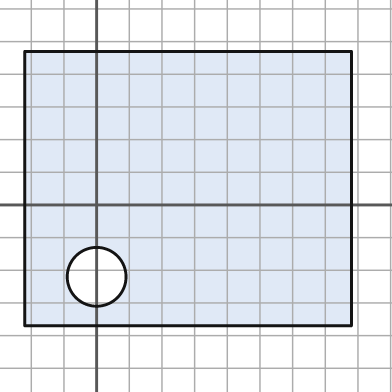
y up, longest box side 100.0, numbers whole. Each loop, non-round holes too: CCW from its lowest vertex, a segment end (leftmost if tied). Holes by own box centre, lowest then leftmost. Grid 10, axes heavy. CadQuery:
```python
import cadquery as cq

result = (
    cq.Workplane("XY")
    .moveTo(-22.0, -37.0)
    .lineTo(78.0, -37.0)
    .lineTo(78.0, 47.0)
    .lineTo(-22.0, 47.0)
    .close()
    .moveTo(0.0, -22.0)
    .circle(9.0)
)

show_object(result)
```